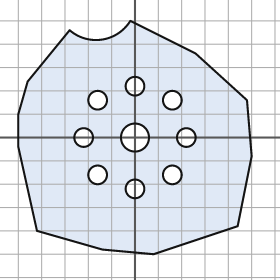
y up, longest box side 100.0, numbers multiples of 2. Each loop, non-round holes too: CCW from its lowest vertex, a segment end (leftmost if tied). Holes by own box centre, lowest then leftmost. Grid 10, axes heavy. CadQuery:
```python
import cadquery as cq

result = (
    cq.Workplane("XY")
    .moveTo(8.0, -50.0)
    .lineTo(44.0, -38.0)
    .lineTo(50.0, -8.0)
    .lineTo(48.0, 16.0)
    .lineTo(26.0, 36.0)
    .lineTo(-2.0, 50.0)
    .threePointArc((-14.0, 42.0), (-28.0, 46.0))
    .lineTo(-46.0, 24.0)
    .lineTo(-50.0, 10.0)
    .lineTo(-50.0, -4.0)
    .lineTo(-42.0, -40.0)
    .lineTo(-14.0, -48.0)
    .close()
    .moveTo(0.0, -22.0)
    .circle(4.0)
    .moveTo(-16.0, -16.0)
    .circle(4.0)
    .moveTo(16.0, -16.0)
    .circle(4.0)
    .moveTo(-22.0, 0.0)
    .circle(4.0)
    .moveTo(0.0, 0.0)
    .circle(6.0)
    .moveTo(22.0, 0.0)
    .circle(4.0)
    .moveTo(-16.0, 16.0)
    .circle(4.0)
    .moveTo(16.0, 16.0)
    .circle(4.0)
    .moveTo(0.0, 22.0)
    .circle(4.0)
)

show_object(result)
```